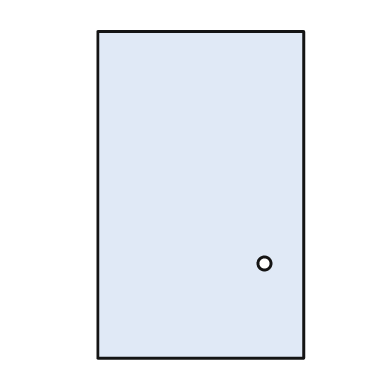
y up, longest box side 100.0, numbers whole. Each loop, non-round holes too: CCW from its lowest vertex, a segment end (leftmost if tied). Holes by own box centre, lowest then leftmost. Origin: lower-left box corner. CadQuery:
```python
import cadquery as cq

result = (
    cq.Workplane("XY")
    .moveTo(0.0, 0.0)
    .lineTo(63.0, 0.0)
    .lineTo(63.0, 100.0)
    .lineTo(0.0, 100.0)
    .close()
    .moveTo(51.0, 29.0)
    .circle(2.0)
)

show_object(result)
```